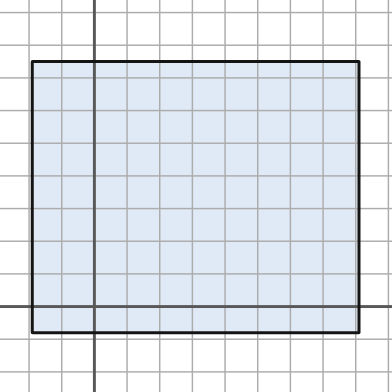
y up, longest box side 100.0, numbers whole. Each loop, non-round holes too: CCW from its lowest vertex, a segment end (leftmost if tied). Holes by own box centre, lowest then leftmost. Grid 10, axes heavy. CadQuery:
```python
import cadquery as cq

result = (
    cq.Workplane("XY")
    .moveTo(-19.0, -8.0)
    .lineTo(81.0, -8.0)
    .lineTo(81.0, 75.0)
    .lineTo(-19.0, 75.0)
    .close()
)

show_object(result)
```